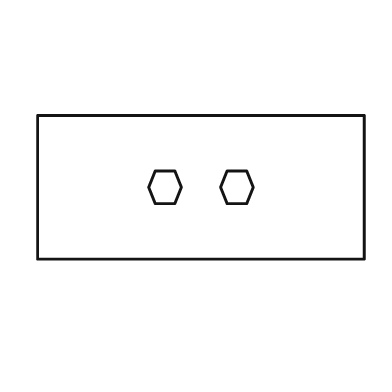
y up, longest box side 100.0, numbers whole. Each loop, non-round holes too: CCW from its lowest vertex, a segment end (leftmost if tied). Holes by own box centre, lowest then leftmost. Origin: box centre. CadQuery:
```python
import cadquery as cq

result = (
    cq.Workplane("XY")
    .moveTo(-50.0, -22.0)
    .lineTo(50.0, -22.0)
    .lineTo(50.0, 22.0)
    .lineTo(-50.0, 22.0)
    .close()
    .moveTo(-14.0, -5.0)
    .lineTo(-8.0, -5.0)
    .lineTo(-6.0, 0.0)
    .lineTo(-8.0, 5.0)
    .lineTo(-14.0, 5.0)
    .lineTo(-16.0, 0.0)
    .close()
    .moveTo(8.0, -5.0)
    .lineTo(14.0, -5.0)
    .lineTo(16.0, 0.0)
    .lineTo(14.0, 5.0)
    .lineTo(8.0, 5.0)
    .lineTo(6.0, 0.0)
    .close()
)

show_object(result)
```